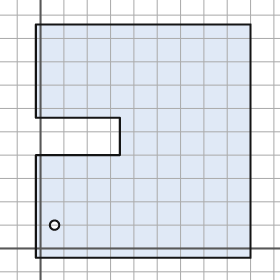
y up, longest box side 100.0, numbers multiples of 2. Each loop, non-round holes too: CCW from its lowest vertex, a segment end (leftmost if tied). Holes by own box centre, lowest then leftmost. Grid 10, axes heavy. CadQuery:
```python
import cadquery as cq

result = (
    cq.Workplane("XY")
    .moveTo(-2.0, -4.0)
    .lineTo(90.0, -4.0)
    .lineTo(90.0, 96.0)
    .lineTo(-2.0, 96.0)
    .lineTo(-2.0, 56.0)
    .lineTo(34.0, 56.0)
    .lineTo(34.0, 40.0)
    .lineTo(-2.0, 40.0)
    .close()
    .moveTo(6.0, 10.0)
    .circle(2.0)
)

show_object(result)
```